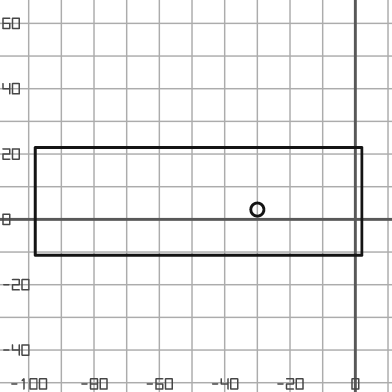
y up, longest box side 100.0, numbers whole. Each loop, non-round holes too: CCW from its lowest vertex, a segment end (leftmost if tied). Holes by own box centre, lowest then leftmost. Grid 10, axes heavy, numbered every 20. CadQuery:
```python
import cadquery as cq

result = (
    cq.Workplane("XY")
    .moveTo(-98.0, -11.0)
    .lineTo(2.0, -11.0)
    .lineTo(2.0, 22.0)
    .lineTo(-98.0, 22.0)
    .close()
    .moveTo(-30.0, 3.0)
    .circle(2.0)
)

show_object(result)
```